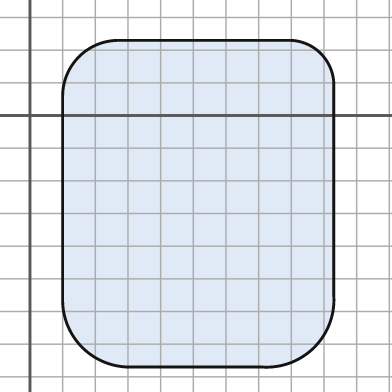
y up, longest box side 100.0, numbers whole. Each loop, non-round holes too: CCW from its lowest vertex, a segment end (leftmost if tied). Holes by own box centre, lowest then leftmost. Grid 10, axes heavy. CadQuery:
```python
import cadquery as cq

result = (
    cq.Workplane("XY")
    .moveTo(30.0, -77.0)
    .lineTo(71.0, -77.0)
    .threePointArc((87.0, -71.0), (93.0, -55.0))
    .lineTo(93.0, 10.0)
    .threePointArc((89.0, 19.0), (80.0, 23.0))
    .lineTo(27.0, 23.0)
    .threePointArc((15.0, 18.0), (10.0, 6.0))
    .lineTo(10.0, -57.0)
    .threePointArc((16.0, -71.0), (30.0, -77.0))
    .close()
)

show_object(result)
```